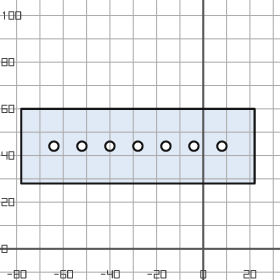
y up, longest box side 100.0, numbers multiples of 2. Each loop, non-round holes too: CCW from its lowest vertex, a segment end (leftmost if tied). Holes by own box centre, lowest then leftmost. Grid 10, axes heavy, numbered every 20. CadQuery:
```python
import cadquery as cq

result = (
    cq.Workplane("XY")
    .moveTo(-78.0, 28.0)
    .lineTo(22.0, 28.0)
    .lineTo(22.0, 60.0)
    .lineTo(-78.0, 60.0)
    .close()
    .moveTo(-64.0, 44.0)
    .circle(2.0)
    .moveTo(-52.0, 44.0)
    .circle(2.0)
    .moveTo(-40.0, 44.0)
    .circle(2.0)
    .moveTo(-28.0, 44.0)
    .circle(2.0)
    .moveTo(-16.0, 44.0)
    .circle(2.0)
    .moveTo(-4.0, 44.0)
    .circle(2.0)
    .moveTo(8.0, 44.0)
    .circle(2.0)
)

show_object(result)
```